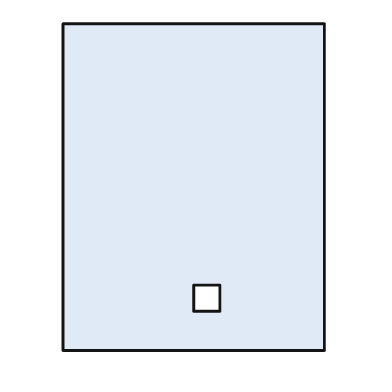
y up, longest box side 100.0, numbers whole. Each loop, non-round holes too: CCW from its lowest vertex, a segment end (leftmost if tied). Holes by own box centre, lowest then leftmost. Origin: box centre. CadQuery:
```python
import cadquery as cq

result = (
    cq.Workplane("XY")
    .moveTo(-40.0, -50.0)
    .lineTo(40.0, -50.0)
    .lineTo(40.0, 50.0)
    .lineTo(-40.0, 50.0)
    .close()
    .moveTo(0.0, -38.0)
    .lineTo(8.0, -38.0)
    .lineTo(8.0, -30.0)
    .lineTo(0.0, -30.0)
    .close()
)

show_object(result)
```